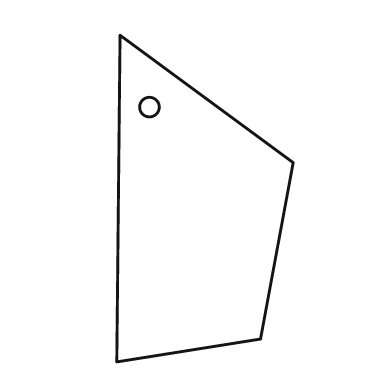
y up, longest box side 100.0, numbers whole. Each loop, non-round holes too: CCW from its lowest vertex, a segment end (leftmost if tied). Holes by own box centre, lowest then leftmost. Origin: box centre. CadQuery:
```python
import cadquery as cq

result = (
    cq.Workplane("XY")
    .moveTo(-27.0, -50.0)
    .lineTo(17.0, -43.0)
    .lineTo(27.0, 11.0)
    .lineTo(-26.0, 50.0)
    .close()
    .moveTo(-17.0, 28.0)
    .circle(3.0)
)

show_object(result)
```